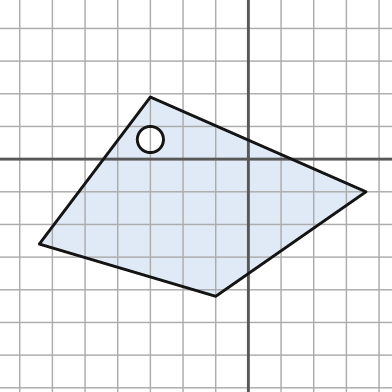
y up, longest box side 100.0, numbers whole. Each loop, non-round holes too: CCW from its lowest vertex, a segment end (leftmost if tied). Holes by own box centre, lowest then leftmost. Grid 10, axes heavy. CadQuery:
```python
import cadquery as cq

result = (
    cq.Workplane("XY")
    .moveTo(-10.0, -42.0)
    .lineTo(36.0, -10.0)
    .lineTo(-30.0, 19.0)
    .lineTo(-64.0, -26.0)
    .close()
    .moveTo(-30.0, 6.0)
    .circle(4.0)
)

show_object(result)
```